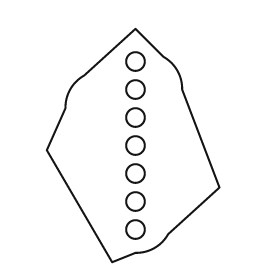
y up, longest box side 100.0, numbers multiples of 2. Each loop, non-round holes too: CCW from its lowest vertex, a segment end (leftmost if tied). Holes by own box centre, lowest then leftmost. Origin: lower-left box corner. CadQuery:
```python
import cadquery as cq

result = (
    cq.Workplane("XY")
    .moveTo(28.0, 0.0)
    .lineTo(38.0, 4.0)
    .threePointArc((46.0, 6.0), (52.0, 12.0))
    .lineTo(74.0, 32.0)
    .lineTo(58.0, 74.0)
    .threePointArc((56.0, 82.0), (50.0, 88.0))
    .lineTo(38.0, 100.0)
    .lineTo(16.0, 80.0)
    .threePointArc((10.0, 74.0), (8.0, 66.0))
    .lineTo(0.0, 48.0)
    .close()
    .moveTo(38.0, 14.0)
    .circle(4.0)
    .moveTo(38.0, 26.0)
    .circle(4.0)
    .moveTo(38.0, 38.0)
    .circle(4.0)
    .moveTo(38.0, 50.0)
    .circle(4.0)
    .moveTo(38.0, 62.0)
    .circle(4.0)
    .moveTo(38.0, 74.0)
    .circle(4.0)
    .moveTo(38.0, 86.0)
    .circle(4.0)
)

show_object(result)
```